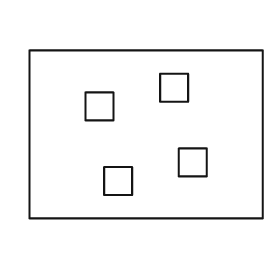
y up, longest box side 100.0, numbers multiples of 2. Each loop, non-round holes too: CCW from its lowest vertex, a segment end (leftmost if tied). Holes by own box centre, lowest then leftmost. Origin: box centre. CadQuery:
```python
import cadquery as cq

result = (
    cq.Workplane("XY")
    .moveTo(-50.0, -36.0)
    .lineTo(50.0, -36.0)
    .lineTo(50.0, 36.0)
    .lineTo(-50.0, 36.0)
    .close()
    .moveTo(-18.0, -26.0)
    .lineTo(-6.0, -26.0)
    .lineTo(-6.0, -14.0)
    .lineTo(-18.0, -14.0)
    .close()
    .moveTo(14.0, -18.0)
    .lineTo(26.0, -18.0)
    .lineTo(26.0, -6.0)
    .lineTo(14.0, -6.0)
    .close()
    .moveTo(-26.0, 6.0)
    .lineTo(-14.0, 6.0)
    .lineTo(-14.0, 18.0)
    .lineTo(-26.0, 18.0)
    .close()
    .moveTo(6.0, 14.0)
    .lineTo(18.0, 14.0)
    .lineTo(18.0, 26.0)
    .lineTo(6.0, 26.0)
    .close()
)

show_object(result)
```